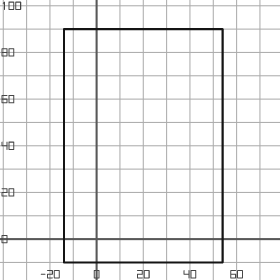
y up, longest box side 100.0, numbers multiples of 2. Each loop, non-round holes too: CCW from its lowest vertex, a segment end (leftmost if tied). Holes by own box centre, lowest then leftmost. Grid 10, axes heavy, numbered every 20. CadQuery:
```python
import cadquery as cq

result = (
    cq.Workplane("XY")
    .moveTo(-14.0, -10.0)
    .lineTo(54.0, -10.0)
    .lineTo(54.0, 90.0)
    .lineTo(-14.0, 90.0)
    .close()
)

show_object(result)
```